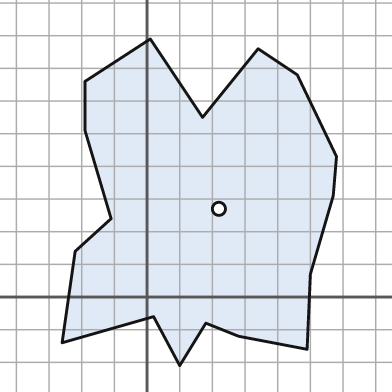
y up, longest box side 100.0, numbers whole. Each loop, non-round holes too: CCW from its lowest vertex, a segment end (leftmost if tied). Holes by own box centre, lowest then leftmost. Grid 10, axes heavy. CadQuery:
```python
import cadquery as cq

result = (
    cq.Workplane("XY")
    .moveTo(10.0, -21.0)
    .lineTo(18.0, -8.0)
    .lineTo(28.0, -12.0)
    .lineTo(49.0, -16.0)
    .lineTo(50.0, 7.0)
    .lineTo(57.0, 31.0)
    .lineTo(58.0, 43.0)
    .lineTo(46.0, 68.0)
    .lineTo(34.0, 76.0)
    .lineTo(17.0, 55.0)
    .lineTo(1.0, 79.0)
    .lineTo(-19.0, 66.0)
    .lineTo(-19.0, 51.0)
    .lineTo(-11.0, 24.0)
    .lineTo(-22.0, 14.0)
    .lineTo(-26.0, -14.0)
    .lineTo(2.0, -6.0)
    .close()
    .moveTo(22.0, 27.0)
    .circle(2.0)
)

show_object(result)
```